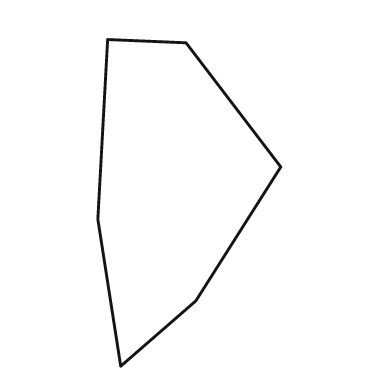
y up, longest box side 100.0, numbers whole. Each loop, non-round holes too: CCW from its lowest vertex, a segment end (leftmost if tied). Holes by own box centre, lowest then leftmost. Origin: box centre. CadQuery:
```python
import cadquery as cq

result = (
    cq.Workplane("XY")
    .moveTo(-21.0, -50.0)
    .lineTo(2.0, -30.0)
    .lineTo(28.0, 11.0)
    .lineTo(-1.0, 49.0)
    .lineTo(-25.0, 50.0)
    .lineTo(-28.0, -5.0)
    .close()
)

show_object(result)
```